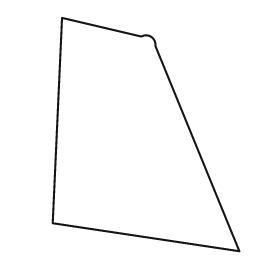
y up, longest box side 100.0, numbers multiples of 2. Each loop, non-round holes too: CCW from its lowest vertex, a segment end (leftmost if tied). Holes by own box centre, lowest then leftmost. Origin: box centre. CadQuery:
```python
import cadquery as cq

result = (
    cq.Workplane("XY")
    .moveTo(40.0, -50.0)
    .lineTo(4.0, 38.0)
    .threePointArc((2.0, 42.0), (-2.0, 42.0))
    .lineTo(-36.0, 50.0)
    .lineTo(-40.0, -38.0)
    .close()
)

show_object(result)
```